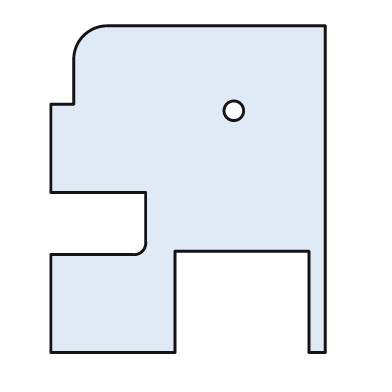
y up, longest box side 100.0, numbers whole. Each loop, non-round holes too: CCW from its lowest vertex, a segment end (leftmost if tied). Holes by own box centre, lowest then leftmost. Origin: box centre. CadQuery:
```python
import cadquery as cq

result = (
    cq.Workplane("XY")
    .moveTo(-42.0, -50.0)
    .lineTo(-4.0, -50.0)
    .lineTo(-4.0, -19.0)
    .lineTo(37.0, -19.0)
    .lineTo(37.0, -50.0)
    .lineTo(42.0, -50.0)
    .lineTo(42.0, 50.0)
    .lineTo(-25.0, 50.0)
    .threePointArc((-32.0, 47.0), (-35.0, 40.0))
    .lineTo(-35.0, 26.0)
    .lineTo(-42.0, 26.0)
    .lineTo(-42.0, -1.0)
    .lineTo(-13.0, -1.0)
    .lineTo(-13.0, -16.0)
    .threePointArc((-14.0, -19.0), (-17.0, -20.0))
    .lineTo(-42.0, -20.0)
    .close()
    .moveTo(14.0, 24.0)
    .circle(3.0)
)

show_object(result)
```